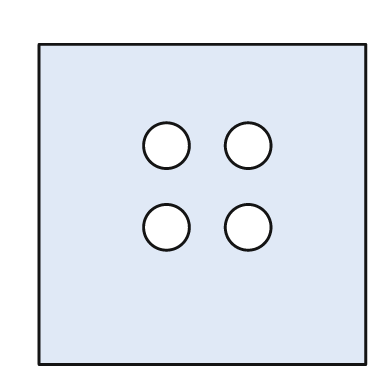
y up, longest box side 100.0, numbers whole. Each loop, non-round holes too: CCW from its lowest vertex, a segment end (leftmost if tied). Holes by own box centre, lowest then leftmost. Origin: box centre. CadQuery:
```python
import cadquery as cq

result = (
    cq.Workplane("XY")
    .moveTo(-50.0, -49.0)
    .lineTo(50.0, -49.0)
    .lineTo(50.0, 49.0)
    .lineTo(-50.0, 49.0)
    .close()
    .moveTo(-11.0, -7.0)
    .circle(7.0)
    .moveTo(14.0, -7.0)
    .circle(7.0)
    .moveTo(-11.0, 18.0)
    .circle(7.0)
    .moveTo(14.0, 18.0)
    .circle(7.0)
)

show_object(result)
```